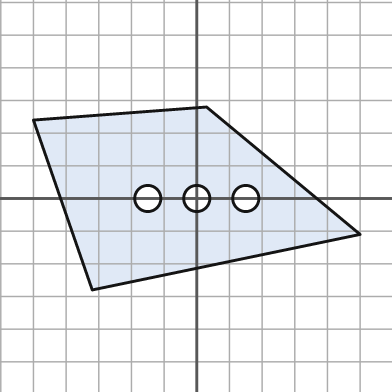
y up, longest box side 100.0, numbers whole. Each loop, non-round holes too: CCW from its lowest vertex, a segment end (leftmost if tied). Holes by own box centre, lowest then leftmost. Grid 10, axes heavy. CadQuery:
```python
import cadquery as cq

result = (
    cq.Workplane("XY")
    .moveTo(-32.0, -28.0)
    .lineTo(50.0, -11.0)
    .lineTo(3.0, 28.0)
    .lineTo(-50.0, 24.0)
    .close()
    .moveTo(-15.0, 0.0)
    .circle(4.0)
    .moveTo(0.0, 0.0)
    .circle(4.0)
    .moveTo(15.0, 0.0)
    .circle(4.0)
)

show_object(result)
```